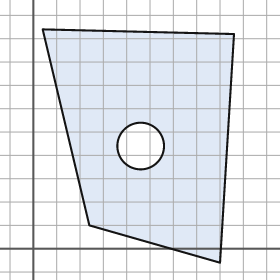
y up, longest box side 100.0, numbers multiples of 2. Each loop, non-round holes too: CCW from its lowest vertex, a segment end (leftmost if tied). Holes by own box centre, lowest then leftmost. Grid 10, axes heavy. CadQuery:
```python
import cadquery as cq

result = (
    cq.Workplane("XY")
    .moveTo(80.0, -6.0)
    .lineTo(86.0, 92.0)
    .lineTo(4.0, 94.0)
    .lineTo(24.0, 10.0)
    .close()
    .moveTo(46.0, 44.0)
    .circle(10.0)
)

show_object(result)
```